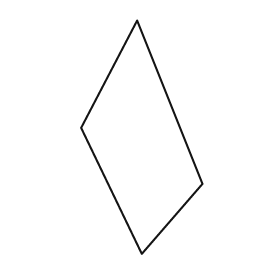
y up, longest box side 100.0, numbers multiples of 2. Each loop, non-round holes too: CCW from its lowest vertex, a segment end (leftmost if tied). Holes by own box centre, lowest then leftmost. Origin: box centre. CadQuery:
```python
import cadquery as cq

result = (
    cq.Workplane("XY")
    .moveTo(0.0, -50.0)
    .lineTo(26.0, -20.0)
    .lineTo(-2.0, 50.0)
    .lineTo(-26.0, 4.0)
    .close()
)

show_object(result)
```